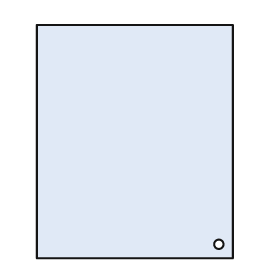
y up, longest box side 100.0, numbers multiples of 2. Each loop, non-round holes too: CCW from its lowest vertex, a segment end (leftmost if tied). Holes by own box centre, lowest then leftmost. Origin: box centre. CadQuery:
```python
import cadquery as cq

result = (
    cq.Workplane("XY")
    .moveTo(-42.0, -50.0)
    .lineTo(42.0, -50.0)
    .lineTo(42.0, 50.0)
    .lineTo(-42.0, 50.0)
    .close()
    .moveTo(36.0, -44.0)
    .circle(2.0)
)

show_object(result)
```